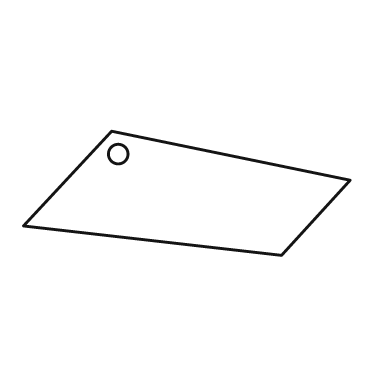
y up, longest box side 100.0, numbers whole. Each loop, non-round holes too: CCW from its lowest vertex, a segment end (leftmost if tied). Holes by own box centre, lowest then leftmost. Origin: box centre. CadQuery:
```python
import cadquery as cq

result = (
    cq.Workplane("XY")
    .moveTo(29.0, -19.0)
    .lineTo(50.0, 4.0)
    .lineTo(-23.0, 19.0)
    .lineTo(-50.0, -10.0)
    .close()
    .moveTo(-21.0, 12.0)
    .circle(3.0)
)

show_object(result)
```